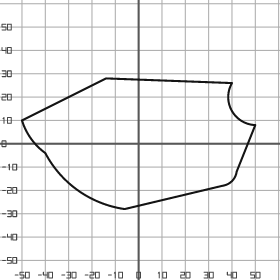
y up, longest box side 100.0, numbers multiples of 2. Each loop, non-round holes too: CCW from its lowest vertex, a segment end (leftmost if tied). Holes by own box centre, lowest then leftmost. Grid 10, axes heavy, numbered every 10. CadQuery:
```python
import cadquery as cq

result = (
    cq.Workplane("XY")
    .moveTo(-6.0, -28.0)
    .lineTo(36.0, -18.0)
    .threePointArc((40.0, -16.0), (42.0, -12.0))
    .lineTo(50.0, 8.0)
    .threePointArc((40.0, 14.0), (40.0, 26.0))
    .lineTo(-14.0, 28.0)
    .lineTo(-50.0, 10.0)
    .threePointArc((-46.0, 2.0), (-40.0, -4.0))
    .threePointArc((-26.0, -20.0), (-6.0, -28.0))
    .close()
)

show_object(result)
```